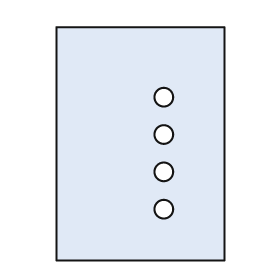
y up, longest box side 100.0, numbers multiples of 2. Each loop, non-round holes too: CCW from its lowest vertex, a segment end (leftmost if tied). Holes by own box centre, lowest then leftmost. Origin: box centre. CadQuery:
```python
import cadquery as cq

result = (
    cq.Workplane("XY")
    .moveTo(-36.0, -50.0)
    .lineTo(36.0, -50.0)
    .lineTo(36.0, 50.0)
    .lineTo(-36.0, 50.0)
    .close()
    .moveTo(10.0, -28.0)
    .circle(4.0)
    .moveTo(10.0, -12.0)
    .circle(4.0)
    .moveTo(10.0, 4.0)
    .circle(4.0)
    .moveTo(10.0, 20.0)
    .circle(4.0)
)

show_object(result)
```